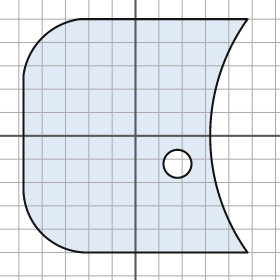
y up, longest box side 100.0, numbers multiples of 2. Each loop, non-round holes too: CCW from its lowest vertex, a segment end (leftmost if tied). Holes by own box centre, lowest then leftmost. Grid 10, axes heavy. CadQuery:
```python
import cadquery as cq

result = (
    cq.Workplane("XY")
    .moveTo(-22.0, -50.0)
    .lineTo(48.0, -50.0)
    .threePointArc((32.0, 0.0), (48.0, 50.0))
    .lineTo(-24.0, 50.0)
    .threePointArc((-40.0, 42.0), (-48.0, 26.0))
    .lineTo(-48.0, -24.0)
    .threePointArc((-40.0, -42.0), (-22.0, -50.0))
    .close()
    .moveTo(18.0, -12.0)
    .circle(6.0)
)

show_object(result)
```